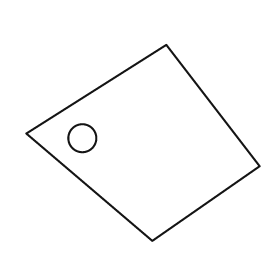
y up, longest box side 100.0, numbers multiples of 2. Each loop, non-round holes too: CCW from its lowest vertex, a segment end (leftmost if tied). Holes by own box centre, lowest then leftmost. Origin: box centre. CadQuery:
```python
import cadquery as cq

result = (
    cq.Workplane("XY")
    .moveTo(4.0, -42.0)
    .lineTo(50.0, -10.0)
    .lineTo(10.0, 42.0)
    .lineTo(-50.0, 4.0)
    .close()
    .moveTo(-26.0, 2.0)
    .circle(6.0)
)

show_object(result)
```